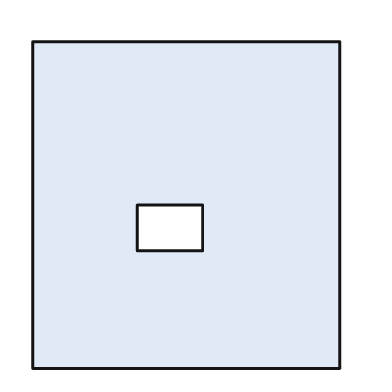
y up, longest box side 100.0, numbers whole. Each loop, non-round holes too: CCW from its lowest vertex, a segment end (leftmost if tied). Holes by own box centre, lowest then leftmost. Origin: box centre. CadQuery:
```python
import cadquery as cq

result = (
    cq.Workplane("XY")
    .moveTo(-47.0, -50.0)
    .lineTo(47.0, -50.0)
    .lineTo(47.0, 50.0)
    .lineTo(-47.0, 50.0)
    .close()
    .moveTo(-15.0, -14.0)
    .lineTo(5.0, -14.0)
    .lineTo(5.0, 0.0)
    .lineTo(-15.0, 0.0)
    .close()
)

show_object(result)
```